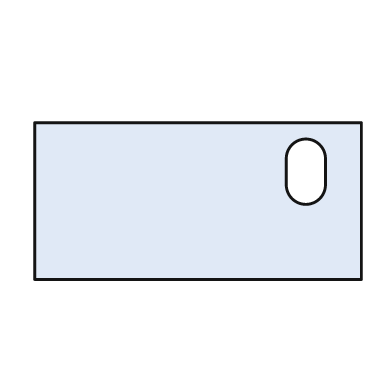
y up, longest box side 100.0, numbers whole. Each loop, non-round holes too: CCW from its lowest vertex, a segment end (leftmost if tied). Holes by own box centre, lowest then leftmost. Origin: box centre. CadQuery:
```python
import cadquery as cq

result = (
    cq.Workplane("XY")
    .moveTo(-50.0, -24.0)
    .lineTo(50.0, -24.0)
    .lineTo(50.0, 24.0)
    .lineTo(-50.0, 24.0)
    .close()
    .moveTo(27.0, 5.0)
    .threePointArc((33.0, -1.0), (39.0, 5.0))
    .lineTo(39.0, 13.0)
    .threePointArc((33.0, 19.0), (27.0, 13.0))
    .close()
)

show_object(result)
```